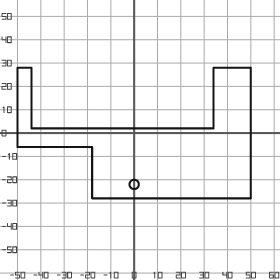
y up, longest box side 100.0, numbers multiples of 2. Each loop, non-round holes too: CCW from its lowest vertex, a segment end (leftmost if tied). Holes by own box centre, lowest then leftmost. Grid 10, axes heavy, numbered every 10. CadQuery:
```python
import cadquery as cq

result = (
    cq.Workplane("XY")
    .moveTo(-18.0, -28.0)
    .lineTo(50.0, -28.0)
    .lineTo(50.0, 28.0)
    .lineTo(34.0, 28.0)
    .lineTo(34.0, 2.0)
    .lineTo(-44.0, 2.0)
    .lineTo(-44.0, 28.0)
    .lineTo(-50.0, 28.0)
    .lineTo(-50.0, -6.0)
    .lineTo(-18.0, -6.0)
    .close()
    .moveTo(0.0, -22.0)
    .circle(2.0)
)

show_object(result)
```